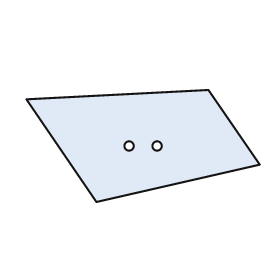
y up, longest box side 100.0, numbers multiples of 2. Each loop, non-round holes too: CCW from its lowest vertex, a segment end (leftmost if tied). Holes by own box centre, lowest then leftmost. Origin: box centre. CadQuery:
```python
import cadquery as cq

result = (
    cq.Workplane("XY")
    .moveTo(-20.0, -24.0)
    .lineTo(50.0, -8.0)
    .lineTo(28.0, 24.0)
    .lineTo(-50.0, 20.0)
    .close()
    .moveTo(-6.0, 0.0)
    .circle(2.0)
    .moveTo(6.0, 0.0)
    .circle(2.0)
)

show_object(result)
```